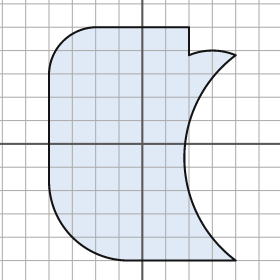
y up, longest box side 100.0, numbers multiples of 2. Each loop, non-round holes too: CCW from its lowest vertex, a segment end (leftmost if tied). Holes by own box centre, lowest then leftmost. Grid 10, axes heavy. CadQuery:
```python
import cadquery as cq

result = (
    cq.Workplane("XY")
    .moveTo(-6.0, -50.0)
    .lineTo(40.0, -50.0)
    .threePointArc((18.0, -6.0), (40.0, 38.0))
    .threePointArc((30.0, 40.0), (20.0, 38.0))
    .lineTo(20.0, 50.0)
    .lineTo(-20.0, 50.0)
    .threePointArc((-34.0, 44.0), (-40.0, 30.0))
    .lineTo(-40.0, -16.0)
    .threePointArc((-30.0, -40.0), (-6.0, -50.0))
    .close()
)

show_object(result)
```